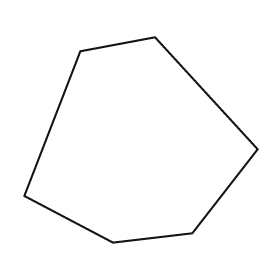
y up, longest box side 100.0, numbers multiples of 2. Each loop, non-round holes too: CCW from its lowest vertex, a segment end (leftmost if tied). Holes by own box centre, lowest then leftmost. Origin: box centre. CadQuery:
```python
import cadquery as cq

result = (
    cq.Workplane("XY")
    .moveTo(-12.0, -44.0)
    .lineTo(22.0, -40.0)
    .lineTo(50.0, -4.0)
    .lineTo(6.0, 44.0)
    .lineTo(-26.0, 38.0)
    .lineTo(-50.0, -24.0)
    .close()
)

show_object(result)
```